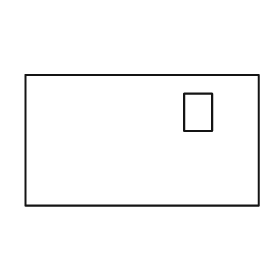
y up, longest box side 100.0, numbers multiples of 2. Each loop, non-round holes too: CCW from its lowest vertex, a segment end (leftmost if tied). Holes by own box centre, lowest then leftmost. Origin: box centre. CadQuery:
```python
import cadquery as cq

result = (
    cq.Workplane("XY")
    .moveTo(-50.0, -28.0)
    .lineTo(50.0, -28.0)
    .lineTo(50.0, 28.0)
    .lineTo(-50.0, 28.0)
    .close()
    .moveTo(18.0, 4.0)
    .lineTo(30.0, 4.0)
    .lineTo(30.0, 20.0)
    .lineTo(18.0, 20.0)
    .close()
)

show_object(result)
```